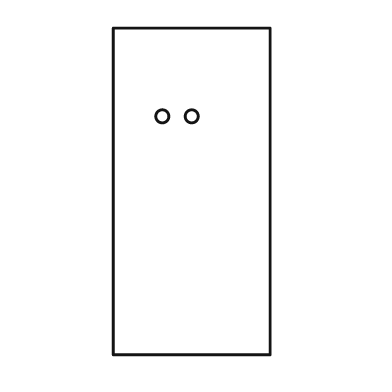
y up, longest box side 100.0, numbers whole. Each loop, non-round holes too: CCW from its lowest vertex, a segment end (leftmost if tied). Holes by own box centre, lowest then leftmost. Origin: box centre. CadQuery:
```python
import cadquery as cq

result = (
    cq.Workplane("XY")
    .moveTo(-24.0, -50.0)
    .lineTo(24.0, -50.0)
    .lineTo(24.0, 50.0)
    .lineTo(-24.0, 50.0)
    .close()
    .moveTo(-9.0, 23.0)
    .circle(2.0)
    .moveTo(0.0, 23.0)
    .circle(2.0)
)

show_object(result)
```